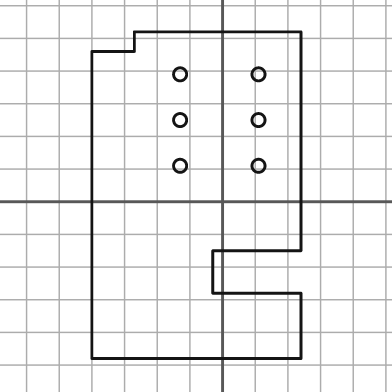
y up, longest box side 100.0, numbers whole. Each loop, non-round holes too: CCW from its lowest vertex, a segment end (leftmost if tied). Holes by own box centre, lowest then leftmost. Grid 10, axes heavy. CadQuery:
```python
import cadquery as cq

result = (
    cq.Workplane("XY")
    .moveTo(-40.0, -48.0)
    .lineTo(24.0, -48.0)
    .lineTo(24.0, -28.0)
    .lineTo(-3.0, -28.0)
    .lineTo(-3.0, -15.0)
    .lineTo(24.0, -15.0)
    .lineTo(24.0, 52.0)
    .lineTo(-27.0, 52.0)
    .lineTo(-27.0, 46.0)
    .lineTo(-40.0, 46.0)
    .close()
    .moveTo(-13.0, 11.0)
    .circle(2.0)
    .moveTo(11.0, 11.0)
    .circle(2.0)
    .moveTo(-13.0, 25.0)
    .circle(2.0)
    .moveTo(11.0, 25.0)
    .circle(2.0)
    .moveTo(-13.0, 39.0)
    .circle(2.0)
    .moveTo(11.0, 39.0)
    .circle(2.0)
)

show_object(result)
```